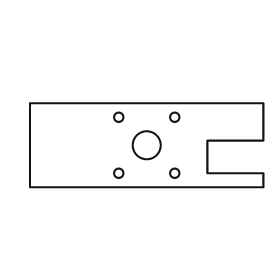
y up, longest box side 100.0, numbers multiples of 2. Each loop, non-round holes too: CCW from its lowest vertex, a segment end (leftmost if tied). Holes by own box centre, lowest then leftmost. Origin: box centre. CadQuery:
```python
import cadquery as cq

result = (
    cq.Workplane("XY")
    .moveTo(-50.0, -18.0)
    .lineTo(50.0, -18.0)
    .lineTo(50.0, -12.0)
    .lineTo(26.0, -12.0)
    .lineTo(26.0, 2.0)
    .lineTo(50.0, 2.0)
    .lineTo(50.0, 18.0)
    .lineTo(-50.0, 18.0)
    .close()
    .moveTo(-12.0, -12.0)
    .circle(2.0)
    .moveTo(12.0, -12.0)
    .circle(2.0)
    .moveTo(0.0, 0.0)
    .circle(6.0)
    .moveTo(-12.0, 12.0)
    .circle(2.0)
    .moveTo(12.0, 12.0)
    .circle(2.0)
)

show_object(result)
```